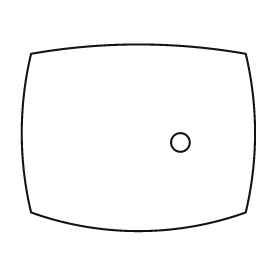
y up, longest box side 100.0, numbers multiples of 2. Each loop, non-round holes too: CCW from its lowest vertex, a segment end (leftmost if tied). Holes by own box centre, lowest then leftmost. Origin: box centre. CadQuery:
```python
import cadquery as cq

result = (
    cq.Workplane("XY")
    .moveTo(-46.0, -32.0)
    .threePointArc((0.0, -40.0), (46.0, -32.0))
    .threePointArc((50.0, 2.0), (46.0, 36.0))
    .threePointArc((0.0, 40.0), (-46.0, 36.0))
    .threePointArc((-50.0, 2.0), (-46.0, -32.0))
    .close()
    .moveTo(18.0, -2.0)
    .circle(4.0)
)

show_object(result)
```